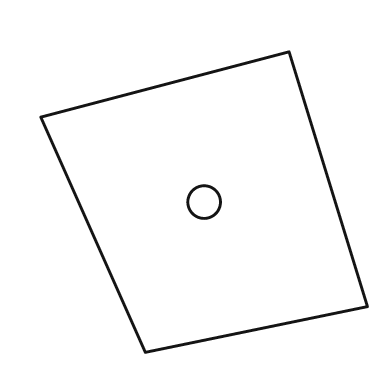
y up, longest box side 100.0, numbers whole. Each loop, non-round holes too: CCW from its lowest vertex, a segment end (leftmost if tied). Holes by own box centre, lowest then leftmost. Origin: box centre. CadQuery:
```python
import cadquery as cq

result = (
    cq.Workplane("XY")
    .moveTo(-18.0, -46.0)
    .lineTo(50.0, -32.0)
    .lineTo(26.0, 46.0)
    .lineTo(-50.0, 26.0)
    .close()
    .moveTo(0.0, 0.0)
    .circle(5.0)
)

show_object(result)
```